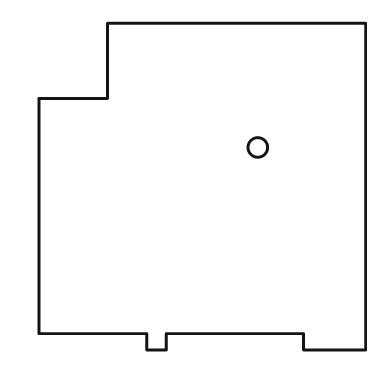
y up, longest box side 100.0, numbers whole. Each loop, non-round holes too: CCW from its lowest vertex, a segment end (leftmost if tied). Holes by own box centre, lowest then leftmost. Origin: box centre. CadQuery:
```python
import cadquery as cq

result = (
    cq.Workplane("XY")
    .moveTo(-17.0, -50.0)
    .lineTo(-11.0, -50.0)
    .lineTo(-11.0, -45.0)
    .lineTo(31.0, -45.0)
    .lineTo(31.0, -50.0)
    .lineTo(50.0, -50.0)
    .lineTo(50.0, 50.0)
    .lineTo(-29.0, 50.0)
    .lineTo(-29.0, 27.0)
    .lineTo(-50.0, 27.0)
    .lineTo(-50.0, -45.0)
    .lineTo(-17.0, -45.0)
    .close()
    .moveTo(17.0, 12.0)
    .circle(3.0)
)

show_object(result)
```